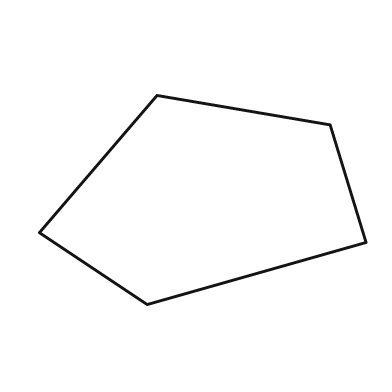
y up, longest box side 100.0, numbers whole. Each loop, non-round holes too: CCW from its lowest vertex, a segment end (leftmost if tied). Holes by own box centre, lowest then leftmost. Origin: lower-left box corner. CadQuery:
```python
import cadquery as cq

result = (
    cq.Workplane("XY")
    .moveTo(33.0, 0.0)
    .lineTo(100.0, 19.0)
    .lineTo(89.0, 55.0)
    .lineTo(36.0, 64.0)
    .lineTo(0.0, 22.0)
    .close()
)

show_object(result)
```